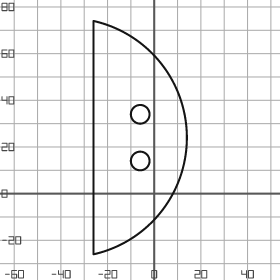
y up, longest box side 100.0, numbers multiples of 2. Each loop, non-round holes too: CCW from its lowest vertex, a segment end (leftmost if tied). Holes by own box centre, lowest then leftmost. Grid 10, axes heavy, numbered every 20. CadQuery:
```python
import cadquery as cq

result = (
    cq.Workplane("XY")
    .moveTo(-26.0, -26.0)
    .threePointArc((14.0, 24.0), (-26.0, 74.0))
    .close()
    .moveTo(-6.0, 14.0)
    .circle(4.0)
    .moveTo(-6.0, 34.0)
    .circle(4.0)
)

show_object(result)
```